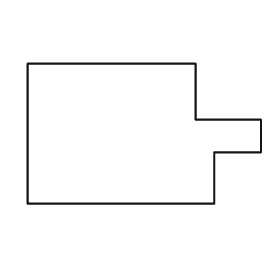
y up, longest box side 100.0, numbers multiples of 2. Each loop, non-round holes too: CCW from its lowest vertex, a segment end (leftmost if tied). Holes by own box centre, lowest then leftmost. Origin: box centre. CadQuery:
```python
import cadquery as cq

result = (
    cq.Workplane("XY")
    .moveTo(-50.0, -30.0)
    .lineTo(30.0, -30.0)
    .lineTo(30.0, -8.0)
    .lineTo(50.0, -8.0)
    .lineTo(50.0, 6.0)
    .lineTo(22.0, 6.0)
    .lineTo(22.0, 30.0)
    .lineTo(-50.0, 30.0)
    .close()
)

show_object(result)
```